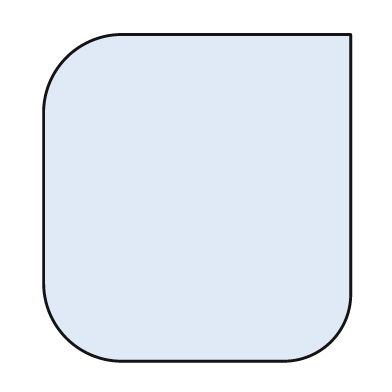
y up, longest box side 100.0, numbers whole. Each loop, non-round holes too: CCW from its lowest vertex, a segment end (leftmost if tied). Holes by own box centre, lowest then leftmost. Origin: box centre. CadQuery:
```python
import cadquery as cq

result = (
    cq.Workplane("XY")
    .moveTo(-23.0, -50.0)
    .lineTo(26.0, -50.0)
    .threePointArc((41.0, -44.0), (47.0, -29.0))
    .lineTo(47.0, 50.0)
    .lineTo(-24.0, 50.0)
    .threePointArc((-40.0, 43.0), (-47.0, 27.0))
    .lineTo(-47.0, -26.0)
    .threePointArc((-40.0, -43.0), (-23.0, -50.0))
    .close()
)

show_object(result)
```